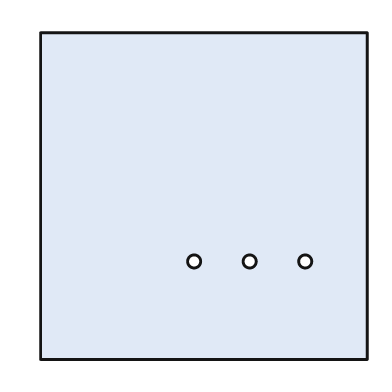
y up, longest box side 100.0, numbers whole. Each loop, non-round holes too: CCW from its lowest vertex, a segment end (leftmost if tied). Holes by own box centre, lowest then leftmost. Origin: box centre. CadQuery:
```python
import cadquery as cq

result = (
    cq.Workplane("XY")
    .moveTo(-50.0, -50.0)
    .lineTo(50.0, -50.0)
    .lineTo(50.0, 50.0)
    .lineTo(-50.0, 50.0)
    .close()
    .moveTo(-3.0, -20.0)
    .circle(2.0)
    .moveTo(14.0, -20.0)
    .circle(2.0)
    .moveTo(31.0, -20.0)
    .circle(2.0)
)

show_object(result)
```